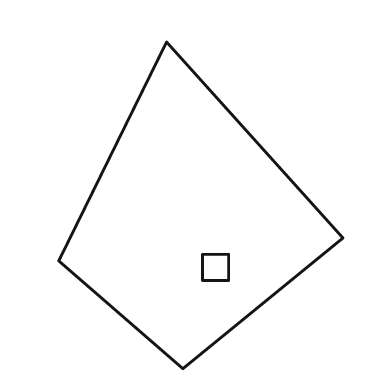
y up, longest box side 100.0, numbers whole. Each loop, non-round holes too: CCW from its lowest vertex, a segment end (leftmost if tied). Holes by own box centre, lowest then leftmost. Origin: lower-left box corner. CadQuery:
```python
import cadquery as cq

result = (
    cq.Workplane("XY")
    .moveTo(38.0, 0.0)
    .lineTo(87.0, 40.0)
    .lineTo(33.0, 100.0)
    .lineTo(0.0, 33.0)
    .close()
    .moveTo(44.0, 27.0)
    .lineTo(52.0, 27.0)
    .lineTo(52.0, 35.0)
    .lineTo(44.0, 35.0)
    .close()
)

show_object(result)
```